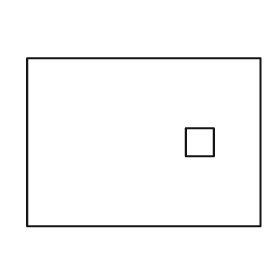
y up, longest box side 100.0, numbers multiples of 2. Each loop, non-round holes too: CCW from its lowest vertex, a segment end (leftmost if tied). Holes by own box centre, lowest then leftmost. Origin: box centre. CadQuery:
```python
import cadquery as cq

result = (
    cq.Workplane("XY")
    .moveTo(-50.0, -36.0)
    .lineTo(50.0, -36.0)
    .lineTo(50.0, 36.0)
    .lineTo(-50.0, 36.0)
    .close()
    .moveTo(18.0, -6.0)
    .lineTo(30.0, -6.0)
    .lineTo(30.0, 6.0)
    .lineTo(18.0, 6.0)
    .close()
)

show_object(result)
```